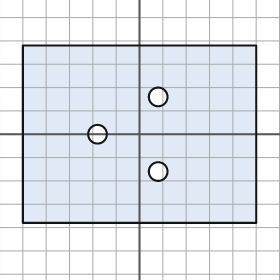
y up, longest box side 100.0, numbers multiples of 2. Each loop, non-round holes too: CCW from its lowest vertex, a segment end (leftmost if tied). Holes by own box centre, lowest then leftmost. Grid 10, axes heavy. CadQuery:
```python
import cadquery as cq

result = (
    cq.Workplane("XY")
    .moveTo(-50.0, -38.0)
    .lineTo(50.0, -38.0)
    .lineTo(50.0, 38.0)
    .lineTo(-50.0, 38.0)
    .close()
    .moveTo(8.0, -16.0)
    .circle(4.0)
    .moveTo(-18.0, 0.0)
    .circle(4.0)
    .moveTo(8.0, 16.0)
    .circle(4.0)
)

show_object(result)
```